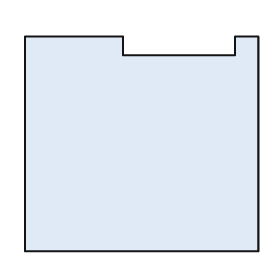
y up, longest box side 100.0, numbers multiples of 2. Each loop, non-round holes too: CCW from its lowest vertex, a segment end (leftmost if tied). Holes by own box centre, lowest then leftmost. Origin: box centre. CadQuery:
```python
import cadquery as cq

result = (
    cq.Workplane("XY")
    .moveTo(-50.0, -46.0)
    .lineTo(50.0, -46.0)
    .lineTo(50.0, 46.0)
    .lineTo(40.0, 46.0)
    .lineTo(40.0, 38.0)
    .lineTo(-8.0, 38.0)
    .lineTo(-8.0, 46.0)
    .lineTo(-50.0, 46.0)
    .close()
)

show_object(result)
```